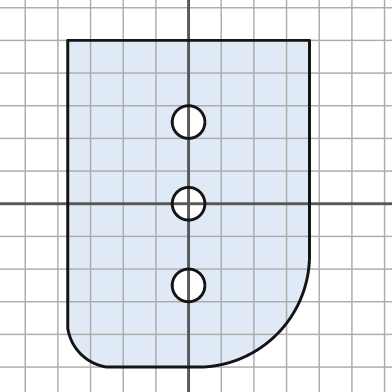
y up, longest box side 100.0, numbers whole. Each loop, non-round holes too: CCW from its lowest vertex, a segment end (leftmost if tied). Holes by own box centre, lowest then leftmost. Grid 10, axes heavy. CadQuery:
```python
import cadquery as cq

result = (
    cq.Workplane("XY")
    .moveTo(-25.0, -50.0)
    .lineTo(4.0, -50.0)
    .threePointArc((27.0, -40.0), (37.0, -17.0))
    .lineTo(37.0, 50.0)
    .lineTo(-37.0, 50.0)
    .lineTo(-37.0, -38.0)
    .threePointArc((-33.0, -46.0), (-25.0, -50.0))
    .close()
    .moveTo(0.0, -25.0)
    .circle(5.0)
    .moveTo(0.0, 0.0)
    .circle(5.0)
    .moveTo(0.0, 25.0)
    .circle(5.0)
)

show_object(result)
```